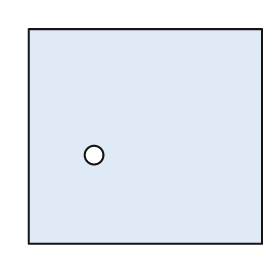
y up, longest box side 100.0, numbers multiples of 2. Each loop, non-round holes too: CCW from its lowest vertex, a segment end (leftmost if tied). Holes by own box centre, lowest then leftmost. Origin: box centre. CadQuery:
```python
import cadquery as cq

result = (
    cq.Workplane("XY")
    .moveTo(-50.0, -46.0)
    .lineTo(50.0, -46.0)
    .lineTo(50.0, 46.0)
    .lineTo(-50.0, 46.0)
    .close()
    .moveTo(-22.0, -8.0)
    .circle(4.0)
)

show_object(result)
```